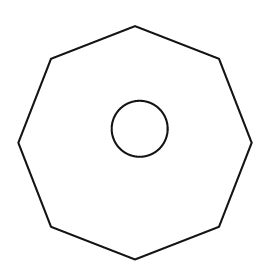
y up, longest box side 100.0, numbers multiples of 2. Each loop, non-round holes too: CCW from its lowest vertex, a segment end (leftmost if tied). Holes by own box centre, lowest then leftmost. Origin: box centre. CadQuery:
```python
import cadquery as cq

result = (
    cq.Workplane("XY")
    .moveTo(0.0, -50.0)
    .lineTo(36.0, -36.0)
    .lineTo(50.0, 0.0)
    .lineTo(36.0, 36.0)
    .lineTo(0.0, 50.0)
    .lineTo(-36.0, 36.0)
    .lineTo(-50.0, 0.0)
    .lineTo(-36.0, -36.0)
    .close()
    .moveTo(2.0, 6.0)
    .circle(12.0)
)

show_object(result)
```